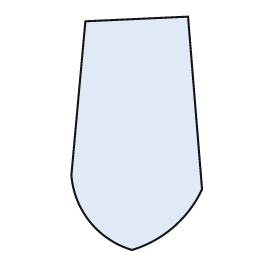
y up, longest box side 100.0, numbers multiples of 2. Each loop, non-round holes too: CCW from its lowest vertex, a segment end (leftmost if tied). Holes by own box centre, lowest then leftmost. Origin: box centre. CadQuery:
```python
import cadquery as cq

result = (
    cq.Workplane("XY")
    .moveTo(-2.0, -50.0)
    .threePointArc((16.0, -40.0), (28.0, -24.0))
    .lineTo(22.0, 50.0)
    .lineTo(-22.0, 48.0)
    .lineTo(-28.0, -18.0)
    .threePointArc((-20.0, -38.0), (-2.0, -50.0))
    .close()
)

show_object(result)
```